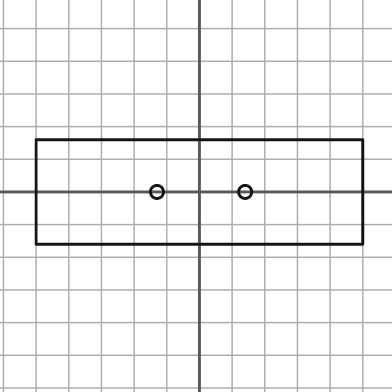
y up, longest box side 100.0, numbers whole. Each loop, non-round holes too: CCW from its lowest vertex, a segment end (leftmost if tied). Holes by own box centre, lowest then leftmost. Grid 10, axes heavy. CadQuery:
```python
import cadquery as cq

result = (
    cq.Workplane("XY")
    .moveTo(-50.0, -16.0)
    .lineTo(50.0, -16.0)
    .lineTo(50.0, 16.0)
    .lineTo(-50.0, 16.0)
    .close()
    .moveTo(-13.0, 0.0)
    .circle(2.0)
    .moveTo(14.0, 0.0)
    .circle(2.0)
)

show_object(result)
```